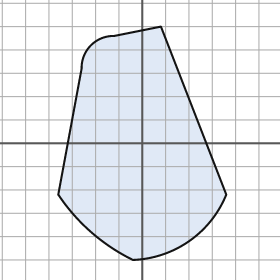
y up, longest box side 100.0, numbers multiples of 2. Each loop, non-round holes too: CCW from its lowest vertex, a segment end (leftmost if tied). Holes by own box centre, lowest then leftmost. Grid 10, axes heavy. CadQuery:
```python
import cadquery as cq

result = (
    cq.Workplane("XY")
    .moveTo(-4.0, -50.0)
    .threePointArc((20.0, -42.0), (36.0, -22.0))
    .lineTo(8.0, 50.0)
    .lineTo(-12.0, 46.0)
    .threePointArc((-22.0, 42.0), (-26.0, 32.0))
    .lineTo(-36.0, -22.0)
    .threePointArc((-22.0, -38.0), (-4.0, -50.0))
    .close()
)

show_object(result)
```